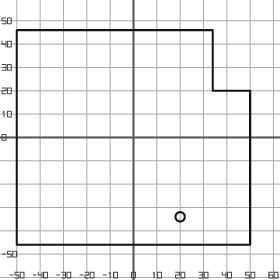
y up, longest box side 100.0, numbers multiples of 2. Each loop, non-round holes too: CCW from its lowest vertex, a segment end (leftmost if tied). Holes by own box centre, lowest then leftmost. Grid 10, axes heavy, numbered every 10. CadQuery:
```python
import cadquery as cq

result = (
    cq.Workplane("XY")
    .moveTo(-50.0, -46.0)
    .lineTo(50.0, -46.0)
    .lineTo(50.0, 20.0)
    .lineTo(34.0, 20.0)
    .lineTo(34.0, 46.0)
    .lineTo(-50.0, 46.0)
    .close()
    .moveTo(20.0, -34.0)
    .circle(2.0)
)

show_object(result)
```